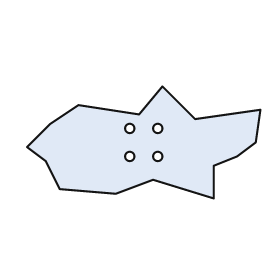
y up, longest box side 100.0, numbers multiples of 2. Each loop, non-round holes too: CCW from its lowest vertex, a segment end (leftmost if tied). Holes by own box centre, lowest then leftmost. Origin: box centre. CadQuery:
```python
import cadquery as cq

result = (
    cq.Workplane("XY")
    .moveTo(30.0, -24.0)
    .lineTo(30.0, -10.0)
    .lineTo(40.0, -6.0)
    .lineTo(48.0, 0.0)
    .lineTo(50.0, 14.0)
    .lineTo(22.0, 10.0)
    .lineTo(8.0, 24.0)
    .lineTo(-2.0, 12.0)
    .lineTo(-28.0, 16.0)
    .lineTo(-40.0, 8.0)
    .lineTo(-50.0, -2.0)
    .lineTo(-42.0, -8.0)
    .lineTo(-36.0, -20.0)
    .lineTo(-12.0, -22.0)
    .lineTo(4.0, -16.0)
    .close()
    .moveTo(-6.0, -6.0)
    .circle(2.0)
    .moveTo(6.0, -6.0)
    .circle(2.0)
    .moveTo(-6.0, 6.0)
    .circle(2.0)
    .moveTo(6.0, 6.0)
    .circle(2.0)
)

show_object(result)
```